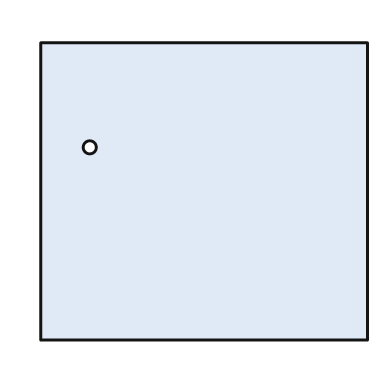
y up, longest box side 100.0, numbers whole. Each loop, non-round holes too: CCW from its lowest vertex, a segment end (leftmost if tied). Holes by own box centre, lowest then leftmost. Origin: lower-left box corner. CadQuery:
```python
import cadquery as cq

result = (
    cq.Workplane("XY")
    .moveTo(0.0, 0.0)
    .lineTo(100.0, 0.0)
    .lineTo(100.0, 91.0)
    .lineTo(0.0, 91.0)
    .close()
    .moveTo(15.0, 59.0)
    .circle(2.0)
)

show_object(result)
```